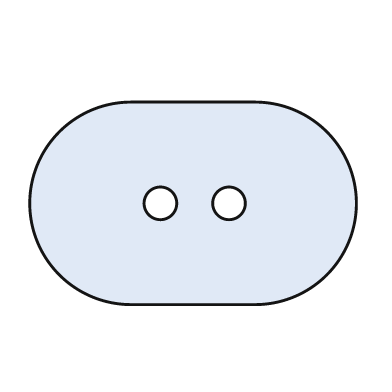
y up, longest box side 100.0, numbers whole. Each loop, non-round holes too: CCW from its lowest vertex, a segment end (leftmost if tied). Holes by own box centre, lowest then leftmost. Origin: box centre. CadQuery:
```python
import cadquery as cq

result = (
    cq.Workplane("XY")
    .moveTo(-19.0, -31.0)
    .lineTo(19.0, -31.0)
    .threePointArc((50.0, 0.0), (19.0, 31.0))
    .lineTo(-19.0, 31.0)
    .threePointArc((-50.0, 0.0), (-19.0, -31.0))
    .close()
    .moveTo(-10.0, 0.0)
    .circle(5.0)
    .moveTo(11.0, 0.0)
    .circle(5.0)
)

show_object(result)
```